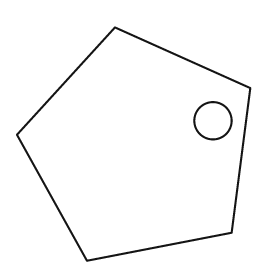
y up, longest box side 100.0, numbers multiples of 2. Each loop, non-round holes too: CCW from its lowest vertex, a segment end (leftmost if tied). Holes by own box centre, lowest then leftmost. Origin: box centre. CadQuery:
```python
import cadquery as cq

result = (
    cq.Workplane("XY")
    .moveTo(-20.0, -50.0)
    .lineTo(42.0, -38.0)
    .lineTo(50.0, 24.0)
    .lineTo(-8.0, 50.0)
    .lineTo(-50.0, 4.0)
    .close()
    .moveTo(34.0, 10.0)
    .circle(8.0)
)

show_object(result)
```